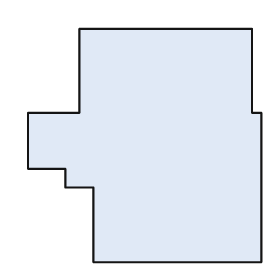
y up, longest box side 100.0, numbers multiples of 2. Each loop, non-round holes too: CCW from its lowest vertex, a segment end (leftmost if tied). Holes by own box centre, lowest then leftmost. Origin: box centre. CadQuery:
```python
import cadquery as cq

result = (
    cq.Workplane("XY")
    .moveTo(-22.0, -50.0)
    .lineTo(50.0, -50.0)
    .lineTo(50.0, 14.0)
    .lineTo(46.0, 14.0)
    .lineTo(46.0, 50.0)
    .lineTo(-28.0, 50.0)
    .lineTo(-28.0, 14.0)
    .lineTo(-50.0, 14.0)
    .lineTo(-50.0, -10.0)
    .lineTo(-34.0, -10.0)
    .lineTo(-34.0, -18.0)
    .lineTo(-22.0, -18.0)
    .close()
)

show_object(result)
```